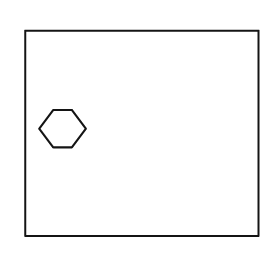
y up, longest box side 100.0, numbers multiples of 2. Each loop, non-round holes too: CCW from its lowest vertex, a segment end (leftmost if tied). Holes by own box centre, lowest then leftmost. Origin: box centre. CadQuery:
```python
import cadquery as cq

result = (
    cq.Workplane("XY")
    .moveTo(-50.0, -44.0)
    .lineTo(50.0, -44.0)
    .lineTo(50.0, 44.0)
    .lineTo(-50.0, 44.0)
    .close()
    .moveTo(-38.0, -6.0)
    .lineTo(-30.0, -6.0)
    .lineTo(-24.0, 2.0)
    .lineTo(-30.0, 10.0)
    .lineTo(-38.0, 10.0)
    .lineTo(-44.0, 2.0)
    .close()
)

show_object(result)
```